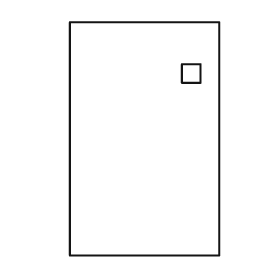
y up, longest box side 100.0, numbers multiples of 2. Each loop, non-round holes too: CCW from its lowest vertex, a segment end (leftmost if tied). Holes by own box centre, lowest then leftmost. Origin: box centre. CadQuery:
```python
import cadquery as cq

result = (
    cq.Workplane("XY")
    .moveTo(-32.0, -50.0)
    .lineTo(32.0, -50.0)
    .lineTo(32.0, 50.0)
    .lineTo(-32.0, 50.0)
    .close()
    .moveTo(16.0, 24.0)
    .lineTo(24.0, 24.0)
    .lineTo(24.0, 32.0)
    .lineTo(16.0, 32.0)
    .close()
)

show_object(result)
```